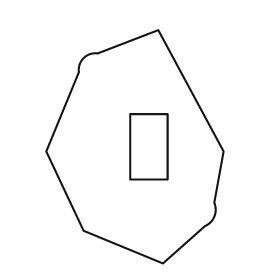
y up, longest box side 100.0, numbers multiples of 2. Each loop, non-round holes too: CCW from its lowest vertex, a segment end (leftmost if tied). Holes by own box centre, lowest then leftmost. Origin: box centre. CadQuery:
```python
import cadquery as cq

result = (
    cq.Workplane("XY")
    .moveTo(12.0, -50.0)
    .lineTo(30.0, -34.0)
    .threePointArc((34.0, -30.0), (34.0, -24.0))
    .lineTo(38.0, -2.0)
    .lineTo(10.0, 50.0)
    .lineTo(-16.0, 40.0)
    .threePointArc((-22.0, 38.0), (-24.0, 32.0))
    .lineTo(-38.0, -2.0)
    .lineTo(-22.0, -36.0)
    .close()
    .moveTo(-2.0, -14.0)
    .lineTo(14.0, -14.0)
    .lineTo(14.0, 14.0)
    .lineTo(-2.0, 14.0)
    .close()
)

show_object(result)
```